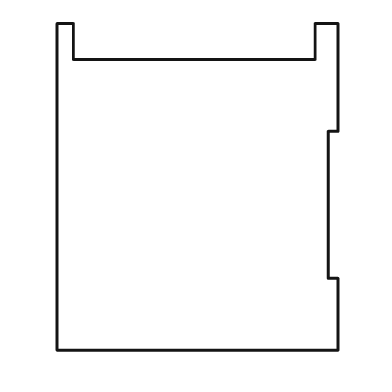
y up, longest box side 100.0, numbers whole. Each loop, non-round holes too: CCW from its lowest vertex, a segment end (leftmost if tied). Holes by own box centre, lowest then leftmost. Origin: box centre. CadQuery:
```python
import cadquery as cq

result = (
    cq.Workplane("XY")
    .moveTo(-43.0, -50.0)
    .lineTo(43.0, -50.0)
    .lineTo(43.0, -28.0)
    .lineTo(40.0, -28.0)
    .lineTo(40.0, 17.0)
    .lineTo(43.0, 17.0)
    .lineTo(43.0, 50.0)
    .lineTo(36.0, 50.0)
    .lineTo(36.0, 39.0)
    .lineTo(-38.0, 39.0)
    .lineTo(-38.0, 50.0)
    .lineTo(-43.0, 50.0)
    .close()
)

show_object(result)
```